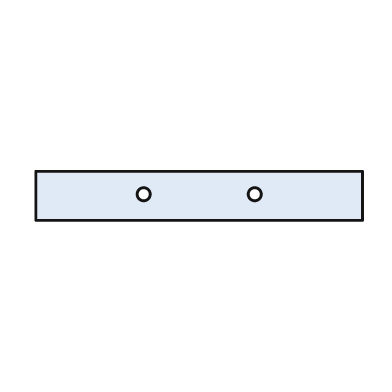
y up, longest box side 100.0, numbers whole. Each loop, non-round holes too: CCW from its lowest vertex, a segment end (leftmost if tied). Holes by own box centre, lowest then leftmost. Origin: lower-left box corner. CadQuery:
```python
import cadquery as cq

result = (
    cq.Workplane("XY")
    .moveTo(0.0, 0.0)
    .lineTo(100.0, 0.0)
    .lineTo(100.0, 15.0)
    .lineTo(0.0, 15.0)
    .close()
    .moveTo(33.0, 8.0)
    .circle(2.0)
    .moveTo(67.0, 8.0)
    .circle(2.0)
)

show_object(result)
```